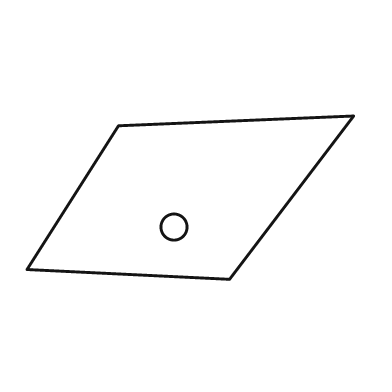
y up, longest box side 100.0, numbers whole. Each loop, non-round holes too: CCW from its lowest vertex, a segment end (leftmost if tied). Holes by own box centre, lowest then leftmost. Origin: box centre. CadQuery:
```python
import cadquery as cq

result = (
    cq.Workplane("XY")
    .moveTo(12.0, -25.0)
    .lineTo(50.0, 25.0)
    .lineTo(-22.0, 22.0)
    .lineTo(-50.0, -22.0)
    .close()
    .moveTo(-5.0, -9.0)
    .circle(4.0)
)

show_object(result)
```